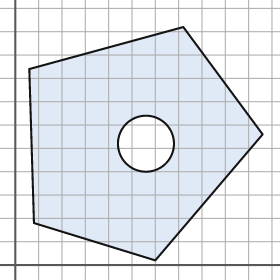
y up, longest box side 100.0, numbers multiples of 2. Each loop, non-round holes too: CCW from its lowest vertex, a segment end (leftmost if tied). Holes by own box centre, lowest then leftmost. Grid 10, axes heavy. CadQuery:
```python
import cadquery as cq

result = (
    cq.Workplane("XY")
    .moveTo(60.0, 2.0)
    .lineTo(106.0, 56.0)
    .lineTo(72.0, 102.0)
    .lineTo(6.0, 84.0)
    .lineTo(8.0, 18.0)
    .close()
    .moveTo(56.0, 52.0)
    .circle(12.0)
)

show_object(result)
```